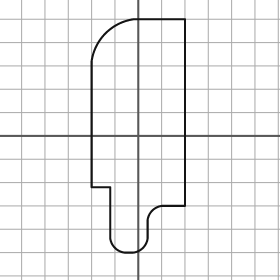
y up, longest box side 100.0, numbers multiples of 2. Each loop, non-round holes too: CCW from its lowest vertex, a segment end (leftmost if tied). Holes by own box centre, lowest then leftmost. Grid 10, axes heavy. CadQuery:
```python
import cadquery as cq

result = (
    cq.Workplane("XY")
    .moveTo(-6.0, -50.0)
    .lineTo(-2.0, -50.0)
    .threePointArc((2.0, -48.0), (4.0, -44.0))
    .lineTo(4.0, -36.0)
    .threePointArc((6.0, -32.0), (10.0, -30.0))
    .lineTo(20.0, -30.0)
    .lineTo(20.0, 50.0)
    .lineTo(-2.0, 50.0)
    .threePointArc((-14.0, 44.0), (-20.0, 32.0))
    .lineTo(-20.0, -22.0)
    .lineTo(-12.0, -22.0)
    .lineTo(-12.0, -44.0)
    .threePointArc((-10.0, -48.0), (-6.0, -50.0))
    .close()
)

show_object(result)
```